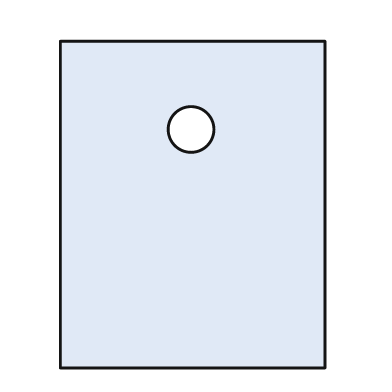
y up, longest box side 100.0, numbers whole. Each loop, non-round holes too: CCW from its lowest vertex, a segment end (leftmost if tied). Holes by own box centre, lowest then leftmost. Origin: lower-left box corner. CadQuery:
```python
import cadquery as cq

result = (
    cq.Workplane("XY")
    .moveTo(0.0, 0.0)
    .lineTo(81.0, 0.0)
    .lineTo(81.0, 100.0)
    .lineTo(0.0, 100.0)
    .close()
    .moveTo(40.0, 73.0)
    .circle(7.0)
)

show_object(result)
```